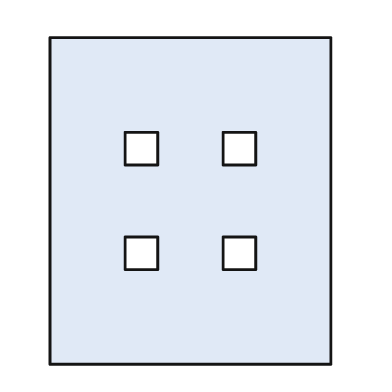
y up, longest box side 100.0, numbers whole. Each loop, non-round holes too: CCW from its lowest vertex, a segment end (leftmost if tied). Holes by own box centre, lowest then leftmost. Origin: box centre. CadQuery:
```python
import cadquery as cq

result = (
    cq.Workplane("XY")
    .moveTo(-43.0, -50.0)
    .lineTo(43.0, -50.0)
    .lineTo(43.0, 50.0)
    .lineTo(-43.0, 50.0)
    .close()
    .moveTo(-20.0, -21.0)
    .lineTo(-10.0, -21.0)
    .lineTo(-10.0, -11.0)
    .lineTo(-20.0, -11.0)
    .close()
    .moveTo(10.0, -21.0)
    .lineTo(20.0, -21.0)
    .lineTo(20.0, -11.0)
    .lineTo(10.0, -11.0)
    .close()
    .moveTo(-20.0, 11.0)
    .lineTo(-10.0, 11.0)
    .lineTo(-10.0, 21.0)
    .lineTo(-20.0, 21.0)
    .close()
    .moveTo(10.0, 11.0)
    .lineTo(20.0, 11.0)
    .lineTo(20.0, 21.0)
    .lineTo(10.0, 21.0)
    .close()
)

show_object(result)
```